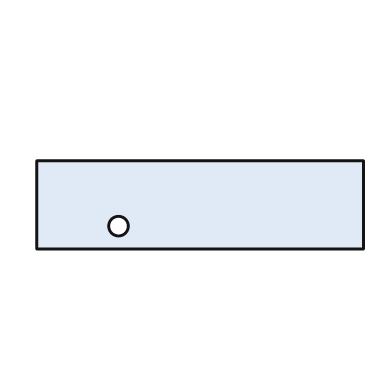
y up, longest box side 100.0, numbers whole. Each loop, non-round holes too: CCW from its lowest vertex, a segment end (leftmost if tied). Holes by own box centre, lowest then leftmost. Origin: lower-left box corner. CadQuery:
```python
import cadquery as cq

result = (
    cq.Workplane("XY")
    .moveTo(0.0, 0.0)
    .lineTo(100.0, 0.0)
    .lineTo(100.0, 27.0)
    .lineTo(0.0, 27.0)
    .close()
    .moveTo(25.0, 7.0)
    .circle(3.0)
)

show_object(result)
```